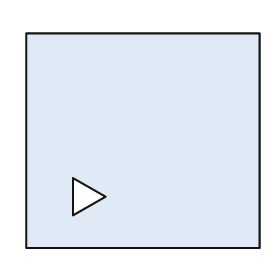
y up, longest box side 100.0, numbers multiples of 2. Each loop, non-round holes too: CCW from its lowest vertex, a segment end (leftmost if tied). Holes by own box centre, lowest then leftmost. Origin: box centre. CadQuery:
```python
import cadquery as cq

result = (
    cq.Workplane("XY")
    .moveTo(-50.0, -46.0)
    .lineTo(50.0, -46.0)
    .lineTo(50.0, 46.0)
    .lineTo(-50.0, 46.0)
    .close()
    .moveTo(-30.0, -32.0)
    .lineTo(-16.0, -24.0)
    .lineTo(-30.0, -16.0)
    .close()
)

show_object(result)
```